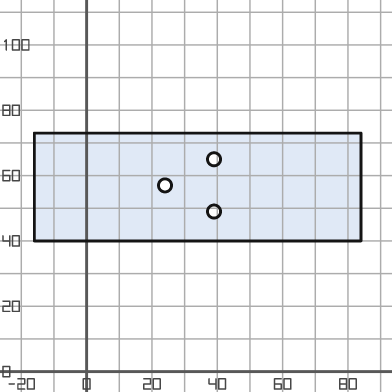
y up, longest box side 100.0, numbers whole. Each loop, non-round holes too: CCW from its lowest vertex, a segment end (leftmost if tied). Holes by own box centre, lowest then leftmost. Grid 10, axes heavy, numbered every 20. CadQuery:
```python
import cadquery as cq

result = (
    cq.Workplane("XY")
    .moveTo(-16.0, 40.0)
    .lineTo(84.0, 40.0)
    .lineTo(84.0, 73.0)
    .lineTo(-16.0, 73.0)
    .close()
    .moveTo(39.0, 49.0)
    .circle(2.0)
    .moveTo(24.0, 57.0)
    .circle(2.0)
    .moveTo(39.0, 65.0)
    .circle(2.0)
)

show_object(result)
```